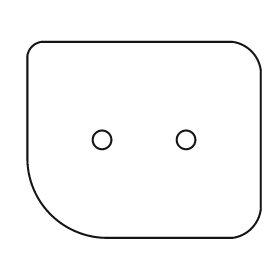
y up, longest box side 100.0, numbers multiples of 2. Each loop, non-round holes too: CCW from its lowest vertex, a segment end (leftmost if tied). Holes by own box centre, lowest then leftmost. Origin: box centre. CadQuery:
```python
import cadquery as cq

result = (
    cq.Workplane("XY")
    .moveTo(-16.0, -42.0)
    .lineTo(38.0, -42.0)
    .threePointArc((46.0, -38.0), (50.0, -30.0))
    .lineTo(50.0, 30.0)
    .threePointArc((46.0, 38.0), (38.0, 42.0))
    .lineTo(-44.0, 42.0)
    .threePointArc((-48.0, 40.0), (-50.0, 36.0))
    .lineTo(-50.0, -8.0)
    .threePointArc((-40.0, -32.0), (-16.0, -42.0))
    .close()
    .moveTo(-18.0, 0.0)
    .circle(4.0)
    .moveTo(18.0, 0.0)
    .circle(4.0)
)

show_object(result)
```